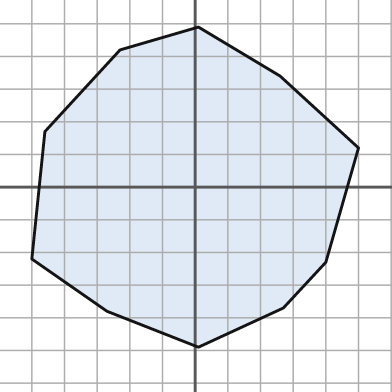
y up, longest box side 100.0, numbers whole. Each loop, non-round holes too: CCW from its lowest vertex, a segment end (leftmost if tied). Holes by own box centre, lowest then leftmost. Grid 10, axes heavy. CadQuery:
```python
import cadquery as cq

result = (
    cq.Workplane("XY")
    .moveTo(1.0, -49.0)
    .lineTo(27.0, -37.0)
    .lineTo(40.0, -23.0)
    .lineTo(50.0, 12.0)
    .lineTo(26.0, 34.0)
    .lineTo(1.0, 49.0)
    .lineTo(-23.0, 42.0)
    .lineTo(-46.0, 17.0)
    .lineTo(-50.0, -22.0)
    .lineTo(-27.0, -38.0)
    .close()
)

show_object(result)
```